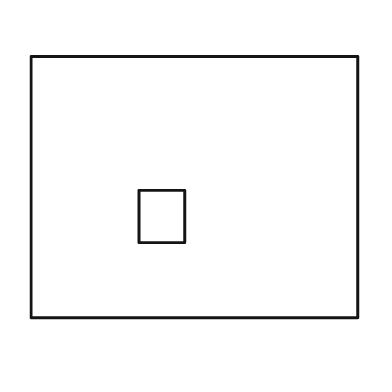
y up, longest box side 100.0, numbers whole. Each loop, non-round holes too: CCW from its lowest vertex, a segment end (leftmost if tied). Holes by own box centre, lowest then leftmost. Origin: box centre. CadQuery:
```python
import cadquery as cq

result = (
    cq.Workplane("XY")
    .moveTo(-50.0, -40.0)
    .lineTo(50.0, -40.0)
    .lineTo(50.0, 40.0)
    .lineTo(-50.0, 40.0)
    .close()
    .moveTo(-17.0, -17.0)
    .lineTo(-3.0, -17.0)
    .lineTo(-3.0, -1.0)
    .lineTo(-17.0, -1.0)
    .close()
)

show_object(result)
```